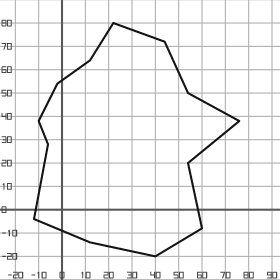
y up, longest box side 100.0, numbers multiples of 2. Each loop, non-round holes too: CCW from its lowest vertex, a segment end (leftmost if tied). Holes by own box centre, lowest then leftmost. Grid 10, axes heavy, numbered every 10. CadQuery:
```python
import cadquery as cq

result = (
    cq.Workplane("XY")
    .moveTo(40.0, -20.0)
    .lineTo(60.0, -8.0)
    .lineTo(54.0, 20.0)
    .lineTo(76.0, 38.0)
    .lineTo(54.0, 50.0)
    .lineTo(44.0, 72.0)
    .lineTo(22.0, 80.0)
    .lineTo(12.0, 64.0)
    .lineTo(-2.0, 54.0)
    .lineTo(-10.0, 38.0)
    .lineTo(-6.0, 28.0)
    .lineTo(-12.0, -4.0)
    .lineTo(12.0, -14.0)
    .close()
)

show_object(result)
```